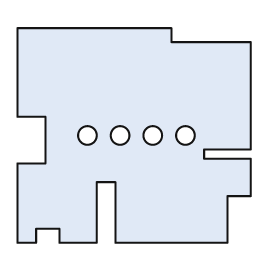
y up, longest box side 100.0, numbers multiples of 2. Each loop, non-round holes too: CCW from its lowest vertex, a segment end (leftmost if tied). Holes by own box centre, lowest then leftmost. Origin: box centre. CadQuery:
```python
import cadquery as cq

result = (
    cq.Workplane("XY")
    .moveTo(-50.0, -46.0)
    .lineTo(-42.0, -46.0)
    .lineTo(-42.0, -40.0)
    .lineTo(-32.0, -40.0)
    .lineTo(-32.0, -46.0)
    .lineTo(-16.0, -46.0)
    .lineTo(-16.0, -20.0)
    .lineTo(-8.0, -20.0)
    .lineTo(-8.0, -46.0)
    .lineTo(40.0, -46.0)
    .lineTo(40.0, -26.0)
    .lineTo(50.0, -26.0)
    .lineTo(50.0, -10.0)
    .lineTo(30.0, -10.0)
    .lineTo(30.0, -6.0)
    .lineTo(50.0, -6.0)
    .lineTo(50.0, 40.0)
    .lineTo(16.0, 40.0)
    .lineTo(16.0, 46.0)
    .lineTo(-50.0, 46.0)
    .lineTo(-50.0, 8.0)
    .lineTo(-38.0, 8.0)
    .lineTo(-38.0, -12.0)
    .lineTo(-50.0, -12.0)
    .close()
    .moveTo(-20.0, 0.0)
    .circle(4.0)
    .moveTo(-6.0, 0.0)
    .circle(4.0)
    .moveTo(8.0, 0.0)
    .circle(4.0)
    .moveTo(22.0, 0.0)
    .circle(4.0)
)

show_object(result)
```